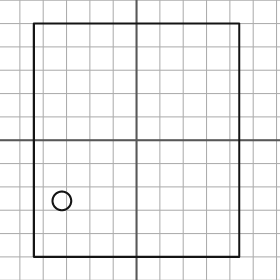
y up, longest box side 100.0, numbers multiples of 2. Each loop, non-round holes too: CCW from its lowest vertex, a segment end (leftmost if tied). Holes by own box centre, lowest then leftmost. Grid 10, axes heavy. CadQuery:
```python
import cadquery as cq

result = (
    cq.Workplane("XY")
    .moveTo(-44.0, -50.0)
    .lineTo(44.0, -50.0)
    .lineTo(44.0, 50.0)
    .lineTo(-44.0, 50.0)
    .close()
    .moveTo(-32.0, -26.0)
    .circle(4.0)
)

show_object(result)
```